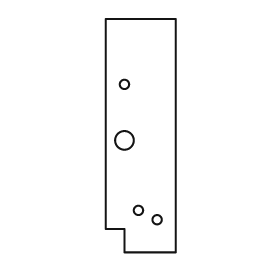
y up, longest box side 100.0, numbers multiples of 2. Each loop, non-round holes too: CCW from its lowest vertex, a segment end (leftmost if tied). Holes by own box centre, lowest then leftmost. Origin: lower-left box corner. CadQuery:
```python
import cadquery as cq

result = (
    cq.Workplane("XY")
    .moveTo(8.0, 0.0)
    .lineTo(30.0, 0.0)
    .lineTo(30.0, 100.0)
    .lineTo(0.0, 100.0)
    .lineTo(0.0, 10.0)
    .lineTo(8.0, 10.0)
    .close()
    .moveTo(22.0, 14.0)
    .circle(2.0)
    .moveTo(14.0, 18.0)
    .circle(2.0)
    .moveTo(8.0, 48.0)
    .circle(4.0)
    .moveTo(8.0, 72.0)
    .circle(2.0)
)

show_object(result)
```